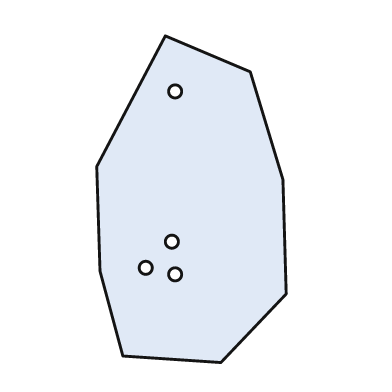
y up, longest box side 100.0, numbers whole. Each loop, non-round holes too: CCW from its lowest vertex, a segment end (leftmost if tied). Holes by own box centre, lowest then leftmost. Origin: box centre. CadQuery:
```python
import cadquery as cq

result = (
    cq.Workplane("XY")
    .moveTo(9.0, -50.0)
    .lineTo(29.0, -29.0)
    .lineTo(28.0, 6.0)
    .lineTo(18.0, 39.0)
    .lineTo(-8.0, 50.0)
    .lineTo(-29.0, 10.0)
    .lineTo(-28.0, -22.0)
    .lineTo(-21.0, -48.0)
    .close()
    .moveTo(-5.0, -23.0)
    .circle(2.0)
    .moveTo(-14.0, -21.0)
    .circle(2.0)
    .moveTo(-6.0, -13.0)
    .circle(2.0)
    .moveTo(-5.0, 33.0)
    .circle(2.0)
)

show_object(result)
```